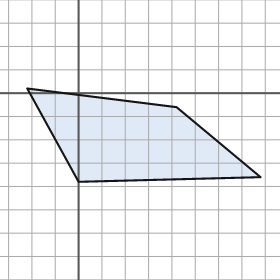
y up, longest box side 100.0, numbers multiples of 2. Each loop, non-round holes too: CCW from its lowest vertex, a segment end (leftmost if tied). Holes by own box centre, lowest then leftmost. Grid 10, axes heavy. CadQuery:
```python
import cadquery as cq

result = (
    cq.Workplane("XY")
    .moveTo(0.0, -38.0)
    .lineTo(78.0, -36.0)
    .lineTo(42.0, -6.0)
    .lineTo(-22.0, 2.0)
    .close()
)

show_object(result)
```